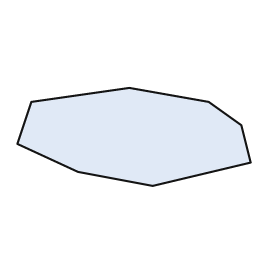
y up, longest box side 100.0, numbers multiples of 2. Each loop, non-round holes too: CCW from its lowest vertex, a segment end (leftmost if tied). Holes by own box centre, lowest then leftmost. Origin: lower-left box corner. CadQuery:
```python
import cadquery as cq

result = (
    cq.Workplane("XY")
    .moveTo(58.0, 0.0)
    .lineTo(100.0, 10.0)
    .lineTo(96.0, 26.0)
    .lineTo(82.0, 36.0)
    .lineTo(48.0, 42.0)
    .lineTo(6.0, 36.0)
    .lineTo(0.0, 18.0)
    .lineTo(26.0, 6.0)
    .close()
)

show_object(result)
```